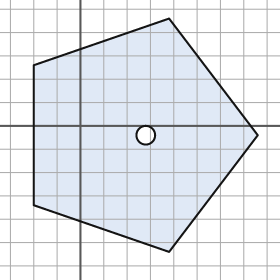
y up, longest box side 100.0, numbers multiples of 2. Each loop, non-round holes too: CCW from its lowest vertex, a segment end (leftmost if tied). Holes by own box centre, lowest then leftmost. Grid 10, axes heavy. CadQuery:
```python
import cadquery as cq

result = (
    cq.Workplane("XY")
    .moveTo(38.0, -54.0)
    .lineTo(76.0, -4.0)
    .lineTo(38.0, 46.0)
    .lineTo(-20.0, 26.0)
    .lineTo(-20.0, -34.0)
    .close()
    .moveTo(28.0, -4.0)
    .circle(4.0)
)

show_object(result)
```